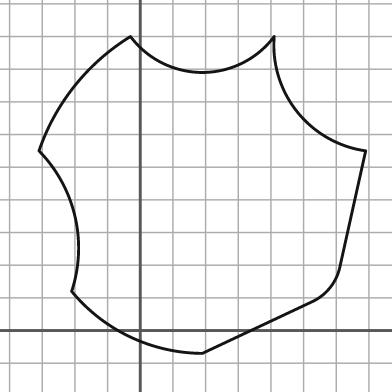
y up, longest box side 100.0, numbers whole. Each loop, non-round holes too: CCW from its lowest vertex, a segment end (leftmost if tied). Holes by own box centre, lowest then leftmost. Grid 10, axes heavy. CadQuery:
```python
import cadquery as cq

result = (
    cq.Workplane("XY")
    .moveTo(19.0, -7.0)
    .lineTo(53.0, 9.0)
    .threePointArc((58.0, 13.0), (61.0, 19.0))
    .lineTo(69.0, 55.0)
    .threePointArc((48.0, 67.0), (41.0, 90.0))
    .threePointArc((19.0, 79.0), (-3.0, 90.0))
    .threePointArc((-20.0, 75.0), (-31.0, 55.0))
    .threePointArc((-20.0, 35.0), (-21.0, 12.0))
    .threePointArc((-3.0, -2.0), (19.0, -7.0))
    .close()
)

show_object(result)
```